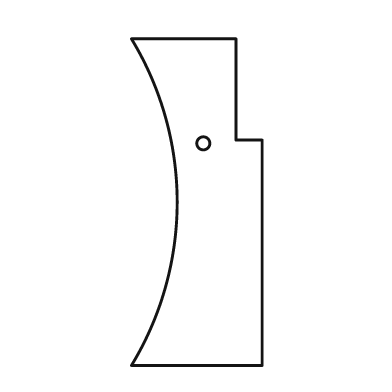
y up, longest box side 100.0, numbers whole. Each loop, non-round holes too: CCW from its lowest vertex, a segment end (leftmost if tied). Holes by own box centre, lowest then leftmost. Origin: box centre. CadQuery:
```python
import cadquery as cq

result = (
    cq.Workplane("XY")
    .moveTo(-20.0, -50.0)
    .lineTo(20.0, -50.0)
    .lineTo(20.0, 19.0)
    .lineTo(12.0, 19.0)
    .lineTo(12.0, 50.0)
    .lineTo(-20.0, 50.0)
    .threePointArc((-6.0, 0.0), (-20.0, -50.0))
    .close()
    .moveTo(2.0, 18.0)
    .circle(2.0)
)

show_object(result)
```